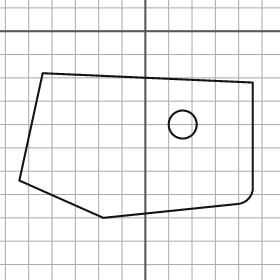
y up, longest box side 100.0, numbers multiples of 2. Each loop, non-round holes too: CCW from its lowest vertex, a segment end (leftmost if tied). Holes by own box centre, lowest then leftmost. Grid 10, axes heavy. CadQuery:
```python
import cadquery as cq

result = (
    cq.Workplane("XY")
    .moveTo(-18.0, -80.0)
    .lineTo(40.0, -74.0)
    .threePointArc((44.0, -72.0), (46.0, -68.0))
    .lineTo(46.0, -22.0)
    .lineTo(-44.0, -18.0)
    .lineTo(-54.0, -64.0)
    .close()
    .moveTo(16.0, -40.0)
    .circle(6.0)
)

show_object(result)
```